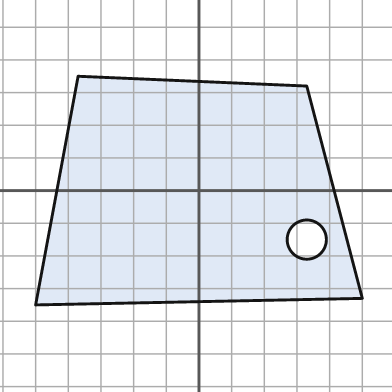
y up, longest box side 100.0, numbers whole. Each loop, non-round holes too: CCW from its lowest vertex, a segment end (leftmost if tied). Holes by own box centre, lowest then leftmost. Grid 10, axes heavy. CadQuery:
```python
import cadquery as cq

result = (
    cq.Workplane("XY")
    .moveTo(-50.0, -35.0)
    .lineTo(50.0, -33.0)
    .lineTo(33.0, 32.0)
    .lineTo(-37.0, 35.0)
    .close()
    .moveTo(33.0, -15.0)
    .circle(6.0)
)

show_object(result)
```